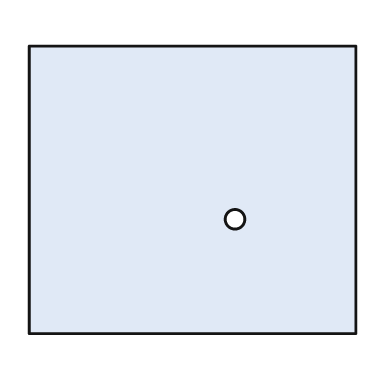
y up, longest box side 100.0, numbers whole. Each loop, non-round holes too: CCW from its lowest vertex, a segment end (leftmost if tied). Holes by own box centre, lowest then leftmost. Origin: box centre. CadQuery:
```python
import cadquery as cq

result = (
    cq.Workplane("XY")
    .moveTo(-50.0, -44.0)
    .lineTo(50.0, -44.0)
    .lineTo(50.0, 44.0)
    .lineTo(-50.0, 44.0)
    .close()
    .moveTo(13.0, -9.0)
    .circle(3.0)
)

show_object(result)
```